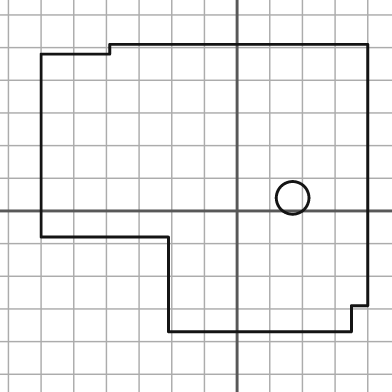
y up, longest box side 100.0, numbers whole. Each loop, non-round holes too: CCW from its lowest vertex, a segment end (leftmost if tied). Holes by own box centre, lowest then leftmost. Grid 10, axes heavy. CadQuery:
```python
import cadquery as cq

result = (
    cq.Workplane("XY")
    .moveTo(-21.0, -37.0)
    .lineTo(35.0, -37.0)
    .lineTo(35.0, -29.0)
    .lineTo(40.0, -29.0)
    .lineTo(40.0, 51.0)
    .lineTo(-39.0, 51.0)
    .lineTo(-39.0, 48.0)
    .lineTo(-60.0, 48.0)
    .lineTo(-60.0, -8.0)
    .lineTo(-21.0, -8.0)
    .close()
    .moveTo(17.0, 4.0)
    .circle(5.0)
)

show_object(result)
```